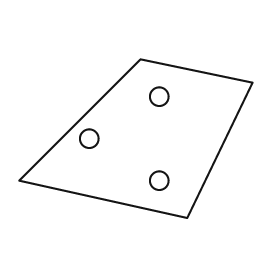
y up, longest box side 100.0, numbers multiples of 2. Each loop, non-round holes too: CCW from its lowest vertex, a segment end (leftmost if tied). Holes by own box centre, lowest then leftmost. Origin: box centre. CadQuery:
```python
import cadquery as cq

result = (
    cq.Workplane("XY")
    .moveTo(22.0, -34.0)
    .lineTo(50.0, 24.0)
    .lineTo(2.0, 34.0)
    .lineTo(-50.0, -18.0)
    .close()
    .moveTo(10.0, -18.0)
    .circle(4.0)
    .moveTo(-20.0, 0.0)
    .circle(4.0)
    .moveTo(10.0, 18.0)
    .circle(4.0)
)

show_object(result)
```